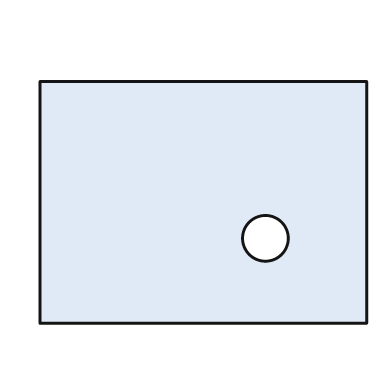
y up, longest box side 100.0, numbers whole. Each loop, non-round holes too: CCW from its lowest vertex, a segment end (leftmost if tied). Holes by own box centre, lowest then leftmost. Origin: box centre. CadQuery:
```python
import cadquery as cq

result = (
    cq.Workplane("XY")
    .moveTo(-50.0, -37.0)
    .lineTo(50.0, -37.0)
    .lineTo(50.0, 37.0)
    .lineTo(-50.0, 37.0)
    .close()
    .moveTo(19.0, -11.0)
    .circle(7.0)
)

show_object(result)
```